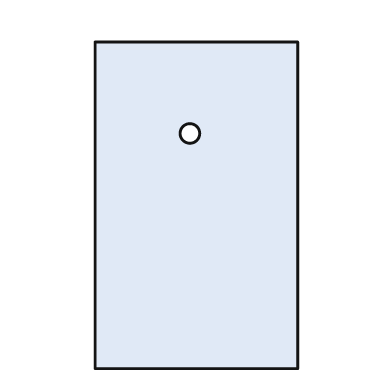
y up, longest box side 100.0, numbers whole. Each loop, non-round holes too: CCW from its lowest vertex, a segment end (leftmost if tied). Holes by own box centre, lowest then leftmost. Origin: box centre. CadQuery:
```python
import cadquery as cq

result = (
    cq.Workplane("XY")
    .moveTo(-31.0, -50.0)
    .lineTo(31.0, -50.0)
    .lineTo(31.0, 50.0)
    .lineTo(-31.0, 50.0)
    .close()
    .moveTo(-2.0, 22.0)
    .circle(3.0)
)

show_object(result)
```